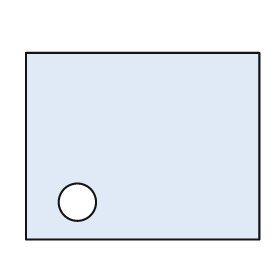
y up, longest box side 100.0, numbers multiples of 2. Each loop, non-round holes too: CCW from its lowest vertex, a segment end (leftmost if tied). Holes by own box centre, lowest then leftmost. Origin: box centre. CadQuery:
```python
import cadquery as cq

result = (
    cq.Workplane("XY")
    .moveTo(-50.0, -40.0)
    .lineTo(50.0, -40.0)
    .lineTo(50.0, 40.0)
    .lineTo(-50.0, 40.0)
    .close()
    .moveTo(-28.0, -24.0)
    .circle(8.0)
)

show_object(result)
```